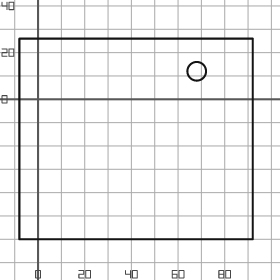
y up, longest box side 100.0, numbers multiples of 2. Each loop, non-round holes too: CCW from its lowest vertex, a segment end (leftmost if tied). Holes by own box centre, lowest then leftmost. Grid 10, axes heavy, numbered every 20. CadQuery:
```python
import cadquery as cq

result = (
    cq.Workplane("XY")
    .moveTo(-8.0, -60.0)
    .lineTo(92.0, -60.0)
    .lineTo(92.0, 26.0)
    .lineTo(-8.0, 26.0)
    .close()
    .moveTo(68.0, 12.0)
    .circle(4.0)
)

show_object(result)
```